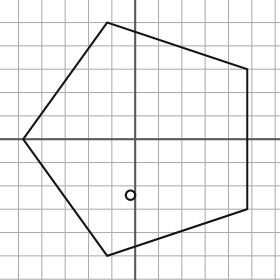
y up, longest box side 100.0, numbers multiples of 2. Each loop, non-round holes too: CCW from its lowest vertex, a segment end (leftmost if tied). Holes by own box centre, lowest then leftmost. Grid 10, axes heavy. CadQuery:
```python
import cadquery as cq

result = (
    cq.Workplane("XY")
    .moveTo(-12.0, -50.0)
    .lineTo(48.0, -30.0)
    .lineTo(48.0, 30.0)
    .lineTo(-12.0, 50.0)
    .lineTo(-48.0, 0.0)
    .close()
    .moveTo(-2.0, -24.0)
    .circle(2.0)
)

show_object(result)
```